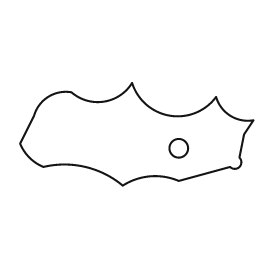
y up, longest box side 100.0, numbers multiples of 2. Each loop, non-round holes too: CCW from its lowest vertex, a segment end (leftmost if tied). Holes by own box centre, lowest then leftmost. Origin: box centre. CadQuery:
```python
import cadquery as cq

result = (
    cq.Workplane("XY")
    .moveTo(-6.0, -22.0)
    .threePointArc((6.0, -18.0), (18.0, -20.0))
    .lineTo(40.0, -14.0)
    .threePointArc((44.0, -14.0), (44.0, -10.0))
    .lineTo(46.0, 0.0)
    .lineTo(50.0, 6.0)
    .threePointArc((40.0, 8.0), (34.0, 16.0))
    .threePointArc((14.0, 8.0), (-2.0, 22.0))
    .threePointArc((-14.0, 14.0), (-28.0, 18.0))
    .threePointArc((-38.0, 16.0), (-44.0, 8.0))
    .lineTo(-50.0, -4.0)
    .threePointArc((-46.0, -10.0), (-40.0, -14.0))
    .threePointArc((-22.0, -14.0), (-6.0, -22.0))
    .close()
    .moveTo(18.0, -6.0)
    .circle(4.0)
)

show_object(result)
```